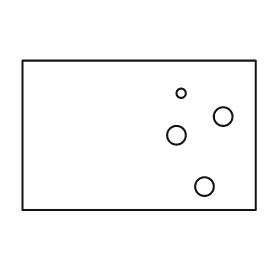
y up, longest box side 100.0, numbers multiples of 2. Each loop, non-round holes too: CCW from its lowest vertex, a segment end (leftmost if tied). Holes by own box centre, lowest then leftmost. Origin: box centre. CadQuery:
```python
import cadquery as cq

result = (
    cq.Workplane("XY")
    .moveTo(-50.0, -32.0)
    .lineTo(50.0, -32.0)
    .lineTo(50.0, 32.0)
    .lineTo(-50.0, 32.0)
    .close()
    .moveTo(28.0, -22.0)
    .circle(4.0)
    .moveTo(16.0, 0.0)
    .circle(4.0)
    .moveTo(36.0, 8.0)
    .circle(4.0)
    .moveTo(18.0, 18.0)
    .circle(2.0)
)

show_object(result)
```